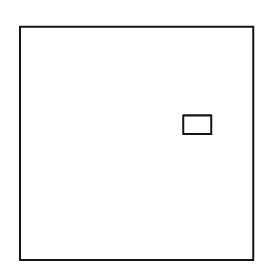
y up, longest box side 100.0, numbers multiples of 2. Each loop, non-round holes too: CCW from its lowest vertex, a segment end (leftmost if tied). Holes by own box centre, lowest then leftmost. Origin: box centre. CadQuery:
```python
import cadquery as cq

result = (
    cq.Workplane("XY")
    .moveTo(-50.0, -50.0)
    .lineTo(50.0, -50.0)
    .lineTo(50.0, 50.0)
    .lineTo(-50.0, 50.0)
    .close()
    .moveTo(20.0, 4.0)
    .lineTo(32.0, 4.0)
    .lineTo(32.0, 12.0)
    .lineTo(20.0, 12.0)
    .close()
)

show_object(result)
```